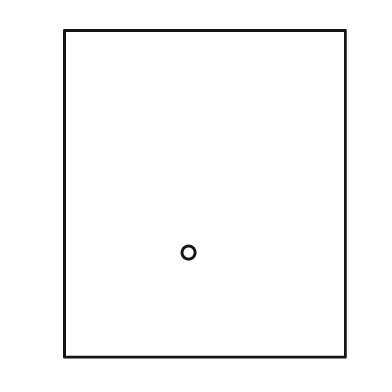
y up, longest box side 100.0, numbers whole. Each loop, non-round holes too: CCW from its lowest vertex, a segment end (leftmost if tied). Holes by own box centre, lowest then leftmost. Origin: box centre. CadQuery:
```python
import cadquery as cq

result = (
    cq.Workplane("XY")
    .moveTo(-43.0, -50.0)
    .lineTo(43.0, -50.0)
    .lineTo(43.0, 50.0)
    .lineTo(-43.0, 50.0)
    .close()
    .moveTo(-5.0, -18.0)
    .circle(2.0)
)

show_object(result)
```